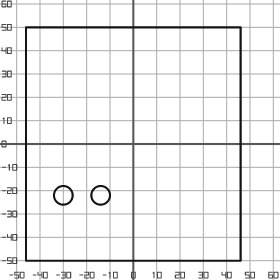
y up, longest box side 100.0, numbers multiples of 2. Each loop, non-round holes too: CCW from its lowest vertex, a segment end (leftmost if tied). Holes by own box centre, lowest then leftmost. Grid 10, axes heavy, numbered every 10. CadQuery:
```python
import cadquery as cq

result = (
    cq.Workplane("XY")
    .moveTo(-46.0, -50.0)
    .lineTo(46.0, -50.0)
    .lineTo(46.0, 50.0)
    .lineTo(-46.0, 50.0)
    .close()
    .moveTo(-30.0, -22.0)
    .circle(4.0)
    .moveTo(-14.0, -22.0)
    .circle(4.0)
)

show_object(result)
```